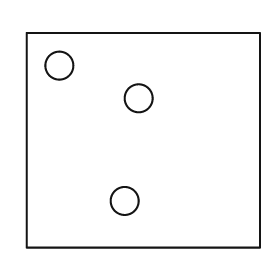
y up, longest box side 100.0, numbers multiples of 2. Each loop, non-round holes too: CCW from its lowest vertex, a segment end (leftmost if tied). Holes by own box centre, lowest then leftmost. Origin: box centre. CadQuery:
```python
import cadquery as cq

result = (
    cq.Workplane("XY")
    .moveTo(-50.0, -46.0)
    .lineTo(50.0, -46.0)
    .lineTo(50.0, 46.0)
    .lineTo(-50.0, 46.0)
    .close()
    .moveTo(-8.0, -26.0)
    .circle(6.0)
    .moveTo(-2.0, 18.0)
    .circle(6.0)
    .moveTo(-36.0, 32.0)
    .circle(6.0)
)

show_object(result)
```